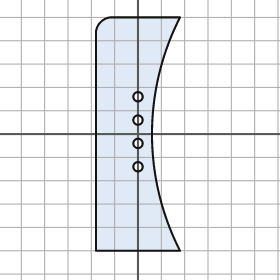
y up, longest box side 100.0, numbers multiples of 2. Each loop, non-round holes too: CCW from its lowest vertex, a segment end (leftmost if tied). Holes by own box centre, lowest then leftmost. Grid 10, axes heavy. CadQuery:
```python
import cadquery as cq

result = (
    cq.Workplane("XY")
    .moveTo(-18.0, -50.0)
    .lineTo(18.0, -50.0)
    .threePointArc((6.0, 0.0), (18.0, 50.0))
    .lineTo(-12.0, 50.0)
    .threePointArc((-16.0, 48.0), (-18.0, 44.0))
    .close()
    .moveTo(0.0, -14.0)
    .circle(2.0)
    .moveTo(0.0, -4.0)
    .circle(2.0)
    .moveTo(0.0, 6.0)
    .circle(2.0)
    .moveTo(0.0, 16.0)
    .circle(2.0)
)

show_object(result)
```